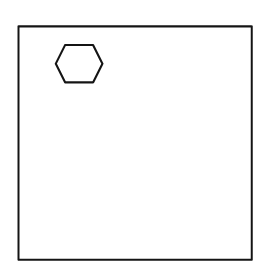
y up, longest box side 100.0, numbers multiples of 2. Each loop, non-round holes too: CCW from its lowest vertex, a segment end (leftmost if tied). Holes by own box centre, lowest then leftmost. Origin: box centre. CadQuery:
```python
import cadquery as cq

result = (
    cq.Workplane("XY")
    .moveTo(-50.0, -50.0)
    .lineTo(50.0, -50.0)
    .lineTo(50.0, 50.0)
    .lineTo(-50.0, 50.0)
    .close()
    .moveTo(-30.0, 26.0)
    .lineTo(-18.0, 26.0)
    .lineTo(-14.0, 34.0)
    .lineTo(-18.0, 42.0)
    .lineTo(-30.0, 42.0)
    .lineTo(-34.0, 34.0)
    .close()
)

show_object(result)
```